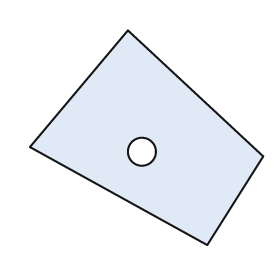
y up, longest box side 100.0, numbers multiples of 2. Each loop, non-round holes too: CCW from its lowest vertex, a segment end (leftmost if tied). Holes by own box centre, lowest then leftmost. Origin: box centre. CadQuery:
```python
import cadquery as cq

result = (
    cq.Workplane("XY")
    .moveTo(26.0, -46.0)
    .lineTo(50.0, -8.0)
    .lineTo(-8.0, 46.0)
    .lineTo(-50.0, -4.0)
    .close()
    .moveTo(-2.0, -6.0)
    .circle(6.0)
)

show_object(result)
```